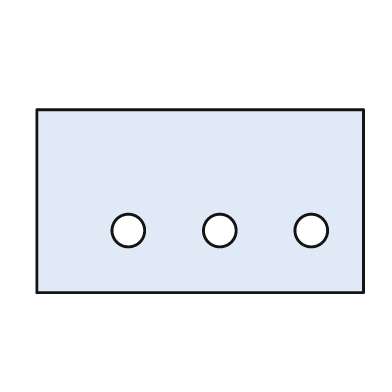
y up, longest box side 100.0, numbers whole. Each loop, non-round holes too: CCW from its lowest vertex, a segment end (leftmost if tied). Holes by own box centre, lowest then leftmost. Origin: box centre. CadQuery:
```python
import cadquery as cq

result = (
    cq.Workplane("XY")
    .moveTo(-50.0, -28.0)
    .lineTo(50.0, -28.0)
    .lineTo(50.0, 28.0)
    .lineTo(-50.0, 28.0)
    .close()
    .moveTo(-22.0, -9.0)
    .circle(5.0)
    .moveTo(6.0, -9.0)
    .circle(5.0)
    .moveTo(34.0, -9.0)
    .circle(5.0)
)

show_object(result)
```